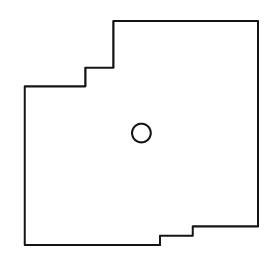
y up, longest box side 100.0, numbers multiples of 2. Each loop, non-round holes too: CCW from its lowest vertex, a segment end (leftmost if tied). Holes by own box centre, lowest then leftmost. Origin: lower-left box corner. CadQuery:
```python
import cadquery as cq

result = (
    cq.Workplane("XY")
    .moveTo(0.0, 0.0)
    .lineTo(58.0, 0.0)
    .lineTo(58.0, 4.0)
    .lineTo(72.0, 4.0)
    .lineTo(72.0, 8.0)
    .lineTo(100.0, 8.0)
    .lineTo(100.0, 96.0)
    .lineTo(38.0, 96.0)
    .lineTo(38.0, 76.0)
    .lineTo(26.0, 76.0)
    .lineTo(26.0, 68.0)
    .lineTo(0.0, 68.0)
    .close()
    .moveTo(50.0, 48.0)
    .circle(4.0)
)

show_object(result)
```